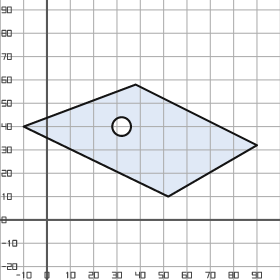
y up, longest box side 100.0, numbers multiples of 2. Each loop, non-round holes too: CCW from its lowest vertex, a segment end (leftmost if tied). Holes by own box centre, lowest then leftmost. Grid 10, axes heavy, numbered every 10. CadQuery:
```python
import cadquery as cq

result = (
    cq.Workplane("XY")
    .moveTo(52.0, 10.0)
    .lineTo(90.0, 32.0)
    .lineTo(38.0, 58.0)
    .lineTo(-10.0, 40.0)
    .close()
    .moveTo(32.0, 40.0)
    .circle(4.0)
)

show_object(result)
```